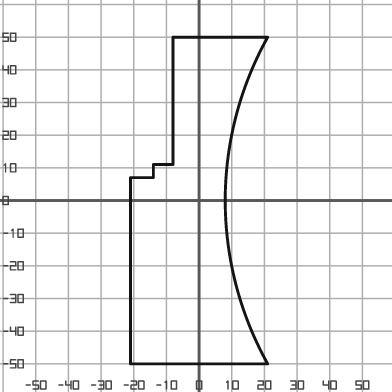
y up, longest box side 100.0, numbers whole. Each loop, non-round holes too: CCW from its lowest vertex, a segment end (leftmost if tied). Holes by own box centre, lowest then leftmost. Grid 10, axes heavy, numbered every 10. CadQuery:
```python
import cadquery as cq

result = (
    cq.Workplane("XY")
    .moveTo(-21.0, -50.0)
    .lineTo(21.0, -50.0)
    .threePointArc((8.0, 0.0), (21.0, 50.0))
    .lineTo(-8.0, 50.0)
    .lineTo(-8.0, 11.0)
    .lineTo(-14.0, 11.0)
    .lineTo(-14.0, 7.0)
    .lineTo(-21.0, 7.0)
    .close()
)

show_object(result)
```